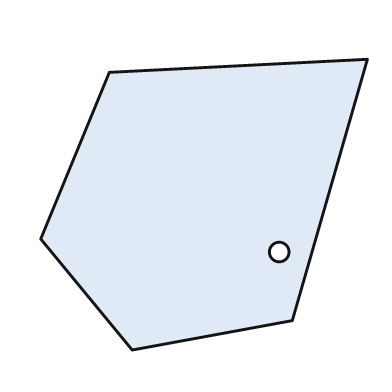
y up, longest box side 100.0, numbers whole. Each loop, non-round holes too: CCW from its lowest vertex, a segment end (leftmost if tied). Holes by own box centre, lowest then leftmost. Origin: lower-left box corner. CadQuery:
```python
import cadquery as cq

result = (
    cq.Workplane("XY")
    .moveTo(28.0, 0.0)
    .lineTo(77.0, 9.0)
    .lineTo(100.0, 89.0)
    .lineTo(21.0, 85.0)
    .lineTo(0.0, 34.0)
    .close()
    .moveTo(73.0, 30.0)
    .circle(3.0)
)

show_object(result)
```